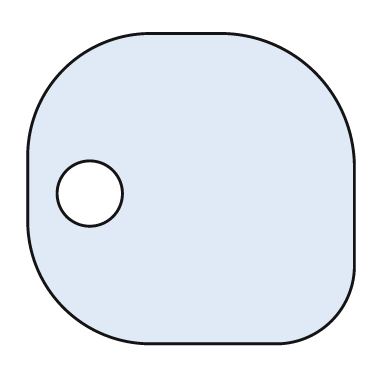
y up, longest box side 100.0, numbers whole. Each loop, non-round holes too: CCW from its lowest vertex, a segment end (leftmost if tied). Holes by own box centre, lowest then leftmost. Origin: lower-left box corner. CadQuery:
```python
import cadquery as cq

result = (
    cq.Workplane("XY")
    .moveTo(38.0, 0.0)
    .lineTo(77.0, 0.0)
    .threePointArc((93.0, 7.0), (100.0, 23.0))
    .lineTo(100.0, 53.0)
    .threePointArc((88.0, 83.0), (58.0, 95.0))
    .lineTo(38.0, 95.0)
    .threePointArc((11.0, 84.0), (0.0, 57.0))
    .lineTo(0.0, 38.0)
    .threePointArc((11.0, 11.0), (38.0, 0.0))
    .close()
    .moveTo(19.0, 46.0)
    .circle(10.0)
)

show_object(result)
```